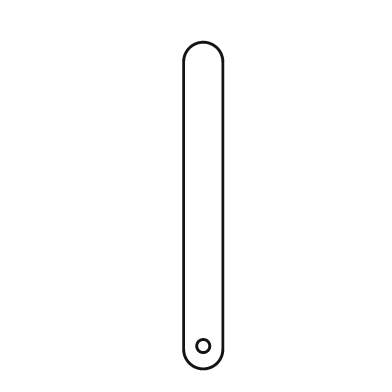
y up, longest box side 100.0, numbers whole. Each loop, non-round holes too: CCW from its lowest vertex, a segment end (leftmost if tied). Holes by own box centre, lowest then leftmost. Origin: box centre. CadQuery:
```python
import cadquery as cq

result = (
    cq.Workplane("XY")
    .moveTo(-6.0, -44.0)
    .threePointArc((0.0, -50.0), (6.0, -44.0))
    .lineTo(6.0, 44.0)
    .threePointArc((0.0, 50.0), (-6.0, 44.0))
    .close()
    .moveTo(0.0, -43.0)
    .circle(2.0)
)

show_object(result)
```